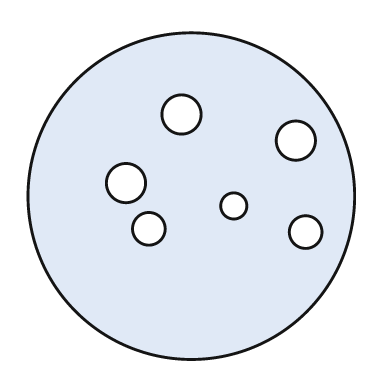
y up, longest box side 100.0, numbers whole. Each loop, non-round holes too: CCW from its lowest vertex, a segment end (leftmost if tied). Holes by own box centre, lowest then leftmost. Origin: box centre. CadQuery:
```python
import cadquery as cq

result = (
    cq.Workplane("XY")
    .moveTo(0.0, 0.0)
    .circle(50.0)
    .moveTo(35.0, -11.0)
    .circle(5.0)
    .moveTo(-13.0, -10.0)
    .circle(5.0)
    .moveTo(13.0, -3.0)
    .circle(4.0)
    .moveTo(-20.0, 4.0)
    .circle(6.0)
    .moveTo(32.0, 17.0)
    .circle(6.0)
    .moveTo(-3.0, 25.0)
    .circle(6.0)
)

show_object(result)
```